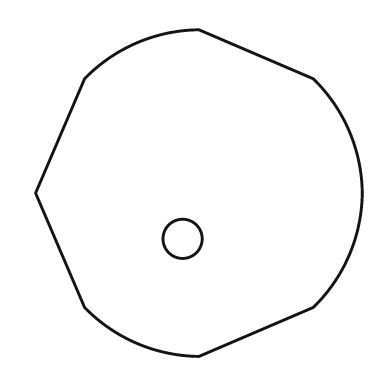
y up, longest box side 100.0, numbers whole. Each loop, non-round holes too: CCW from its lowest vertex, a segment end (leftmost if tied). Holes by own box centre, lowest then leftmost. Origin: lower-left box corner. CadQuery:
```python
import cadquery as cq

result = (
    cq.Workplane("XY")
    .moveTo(50.0, 0.0)
    .lineTo(85.0, 15.0)
    .threePointArc((96.0, 31.0), (100.0, 50.0))
    .threePointArc((96.0, 69.0), (85.0, 85.0))
    .lineTo(50.0, 100.0)
    .threePointArc((31.0, 96.0), (15.0, 85.0))
    .lineTo(0.0, 50.0)
    .lineTo(15.0, 15.0)
    .threePointArc((31.0, 4.0), (50.0, 0.0))
    .close()
    .moveTo(45.0, 36.0)
    .circle(6.0)
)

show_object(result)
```